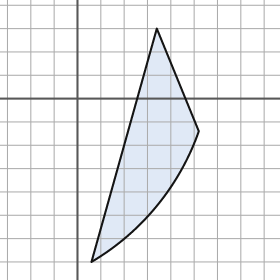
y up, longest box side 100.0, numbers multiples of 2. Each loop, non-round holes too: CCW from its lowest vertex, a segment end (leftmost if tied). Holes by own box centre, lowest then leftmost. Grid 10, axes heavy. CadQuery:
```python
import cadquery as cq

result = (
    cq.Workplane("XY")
    .moveTo(6.0, -70.0)
    .threePointArc((34.0, -46.0), (52.0, -14.0))
    .lineTo(34.0, 30.0)
    .close()
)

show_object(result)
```